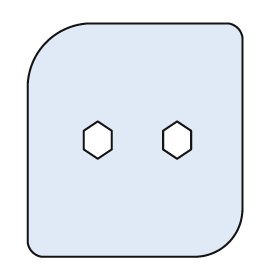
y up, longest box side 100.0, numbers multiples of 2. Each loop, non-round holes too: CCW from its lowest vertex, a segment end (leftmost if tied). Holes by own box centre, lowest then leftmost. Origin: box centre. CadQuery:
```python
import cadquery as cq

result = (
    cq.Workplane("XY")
    .moveTo(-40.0, -50.0)
    .lineTo(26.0, -50.0)
    .threePointArc((40.0, -44.0), (46.0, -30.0))
    .lineTo(46.0, 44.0)
    .threePointArc((44.0, 48.0), (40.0, 50.0))
    .lineTo(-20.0, 50.0)
    .threePointArc((-38.0, 42.0), (-46.0, 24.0))
    .lineTo(-46.0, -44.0)
    .threePointArc((-44.0, -48.0), (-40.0, -50.0))
    .close()
    .moveTo(-16.0, -8.0)
    .lineTo(-10.0, -4.0)
    .lineTo(-10.0, 4.0)
    .lineTo(-16.0, 8.0)
    .lineTo(-22.0, 4.0)
    .lineTo(-22.0, -4.0)
    .close()
    .moveTo(18.0, -8.0)
    .lineTo(24.0, -4.0)
    .lineTo(24.0, 4.0)
    .lineTo(18.0, 8.0)
    .lineTo(12.0, 4.0)
    .lineTo(12.0, -4.0)
    .close()
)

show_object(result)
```